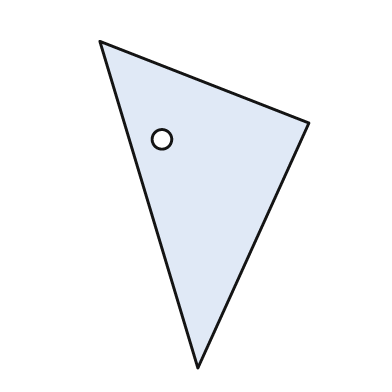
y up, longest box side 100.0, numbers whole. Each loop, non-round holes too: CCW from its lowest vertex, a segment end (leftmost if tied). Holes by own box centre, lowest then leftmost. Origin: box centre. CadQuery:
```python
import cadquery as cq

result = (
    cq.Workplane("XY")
    .moveTo(-2.0, -50.0)
    .lineTo(32.0, 25.0)
    .lineTo(-32.0, 50.0)
    .close()
    .moveTo(-13.0, 20.0)
    .circle(3.0)
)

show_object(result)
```